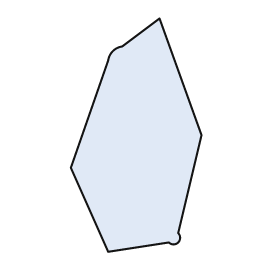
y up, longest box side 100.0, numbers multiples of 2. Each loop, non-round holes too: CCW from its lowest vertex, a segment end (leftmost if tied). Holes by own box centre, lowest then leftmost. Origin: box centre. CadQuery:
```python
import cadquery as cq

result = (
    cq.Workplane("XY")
    .moveTo(-12.0, -50.0)
    .lineTo(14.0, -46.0)
    .threePointArc((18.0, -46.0), (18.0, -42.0))
    .lineTo(28.0, 0.0)
    .lineTo(10.0, 50.0)
    .lineTo(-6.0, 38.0)
    .threePointArc((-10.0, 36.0), (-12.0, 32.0))
    .lineTo(-28.0, -14.0)
    .close()
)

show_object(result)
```